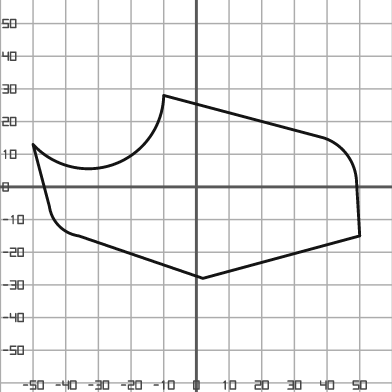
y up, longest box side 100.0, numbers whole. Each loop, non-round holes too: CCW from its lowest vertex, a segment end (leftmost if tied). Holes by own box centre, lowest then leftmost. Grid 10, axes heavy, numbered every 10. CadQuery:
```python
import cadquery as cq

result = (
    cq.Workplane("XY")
    .moveTo(2.0, -28.0)
    .lineTo(50.0, -15.0)
    .lineTo(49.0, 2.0)
    .threePointArc((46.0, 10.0), (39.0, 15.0))
    .lineTo(-10.0, 28.0)
    .threePointArc((-25.0, 7.0), (-50.0, 13.0))
    .lineTo(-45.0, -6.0)
    .threePointArc((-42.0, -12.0), (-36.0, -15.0))
    .close()
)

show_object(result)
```